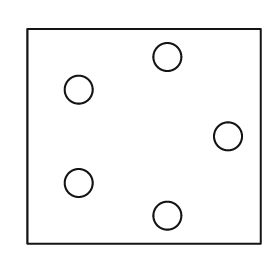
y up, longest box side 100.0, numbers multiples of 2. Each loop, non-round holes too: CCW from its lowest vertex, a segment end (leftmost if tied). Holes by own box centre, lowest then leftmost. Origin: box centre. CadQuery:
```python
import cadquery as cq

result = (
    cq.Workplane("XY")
    .moveTo(-50.0, -46.0)
    .lineTo(50.0, -46.0)
    .lineTo(50.0, 46.0)
    .lineTo(-50.0, 46.0)
    .close()
    .moveTo(10.0, -34.0)
    .circle(6.0)
    .moveTo(-28.0, -20.0)
    .circle(6.0)
    .moveTo(36.0, 0.0)
    .circle(6.0)
    .moveTo(-28.0, 20.0)
    .circle(6.0)
    .moveTo(10.0, 34.0)
    .circle(6.0)
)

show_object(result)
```